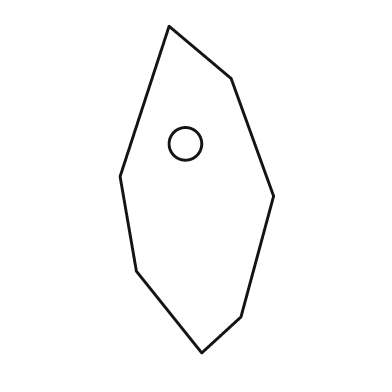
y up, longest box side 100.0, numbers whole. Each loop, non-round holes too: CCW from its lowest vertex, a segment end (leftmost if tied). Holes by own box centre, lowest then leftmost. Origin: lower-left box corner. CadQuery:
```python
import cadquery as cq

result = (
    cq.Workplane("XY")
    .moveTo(25.0, 0.0)
    .lineTo(37.0, 11.0)
    .lineTo(47.0, 48.0)
    .lineTo(34.0, 84.0)
    .lineTo(15.0, 100.0)
    .lineTo(0.0, 54.0)
    .lineTo(5.0, 25.0)
    .close()
    .moveTo(20.0, 64.0)
    .circle(5.0)
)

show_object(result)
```